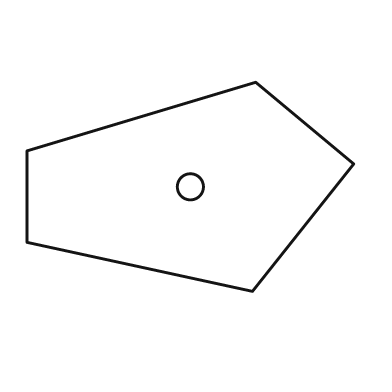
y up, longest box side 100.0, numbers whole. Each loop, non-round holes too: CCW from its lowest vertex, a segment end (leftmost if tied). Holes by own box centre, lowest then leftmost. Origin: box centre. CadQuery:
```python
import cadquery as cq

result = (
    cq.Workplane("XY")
    .moveTo(19.0, -32.0)
    .lineTo(50.0, 7.0)
    .lineTo(20.0, 32.0)
    .lineTo(-50.0, 11.0)
    .lineTo(-50.0, -17.0)
    .close()
    .moveTo(0.0, 0.0)
    .circle(4.0)
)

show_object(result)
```